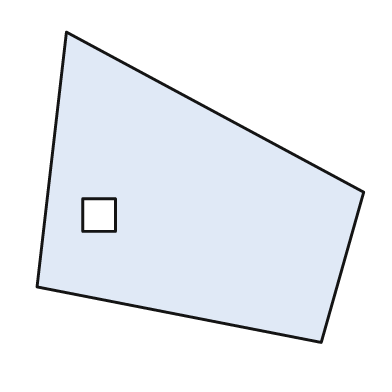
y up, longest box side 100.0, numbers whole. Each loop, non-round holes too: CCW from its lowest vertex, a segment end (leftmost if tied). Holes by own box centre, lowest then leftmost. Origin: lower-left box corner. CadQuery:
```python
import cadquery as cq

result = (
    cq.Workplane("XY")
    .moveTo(87.0, 0.0)
    .lineTo(100.0, 46.0)
    .lineTo(9.0, 95.0)
    .lineTo(0.0, 17.0)
    .close()
    .moveTo(14.0, 34.0)
    .lineTo(24.0, 34.0)
    .lineTo(24.0, 44.0)
    .lineTo(14.0, 44.0)
    .close()
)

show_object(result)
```